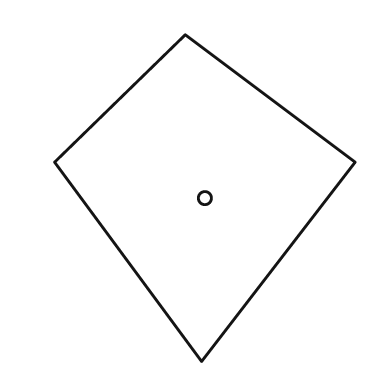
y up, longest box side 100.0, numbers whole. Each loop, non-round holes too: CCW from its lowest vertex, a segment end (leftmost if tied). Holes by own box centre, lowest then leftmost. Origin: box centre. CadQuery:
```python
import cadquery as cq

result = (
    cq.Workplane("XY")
    .moveTo(-1.0, -50.0)
    .lineTo(46.0, 11.0)
    .lineTo(-6.0, 50.0)
    .lineTo(-46.0, 11.0)
    .close()
    .moveTo(0.0, 0.0)
    .circle(2.0)
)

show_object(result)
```